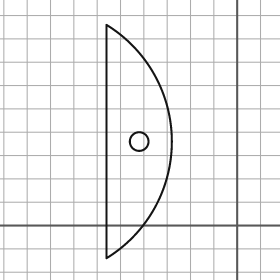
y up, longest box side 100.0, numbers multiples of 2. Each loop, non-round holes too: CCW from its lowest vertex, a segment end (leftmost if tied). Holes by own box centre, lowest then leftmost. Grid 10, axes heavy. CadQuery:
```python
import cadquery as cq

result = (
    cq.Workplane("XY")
    .moveTo(-56.0, -14.0)
    .threePointArc((-28.0, 36.0), (-56.0, 86.0))
    .close()
    .moveTo(-42.0, 36.0)
    .circle(4.0)
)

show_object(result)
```